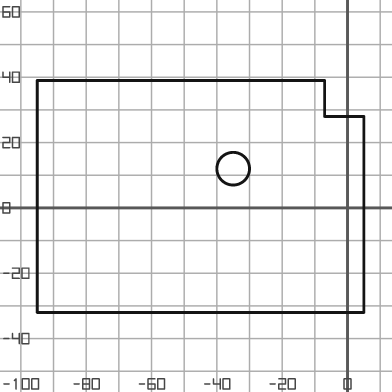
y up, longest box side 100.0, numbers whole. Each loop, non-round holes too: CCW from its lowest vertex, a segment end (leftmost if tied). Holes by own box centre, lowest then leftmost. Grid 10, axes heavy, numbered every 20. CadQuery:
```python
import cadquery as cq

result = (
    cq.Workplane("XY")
    .moveTo(-95.0, -32.0)
    .lineTo(5.0, -32.0)
    .lineTo(5.0, 28.0)
    .lineTo(-7.0, 28.0)
    .lineTo(-7.0, 39.0)
    .lineTo(-95.0, 39.0)
    .close()
    .moveTo(-35.0, 12.0)
    .circle(5.0)
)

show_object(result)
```